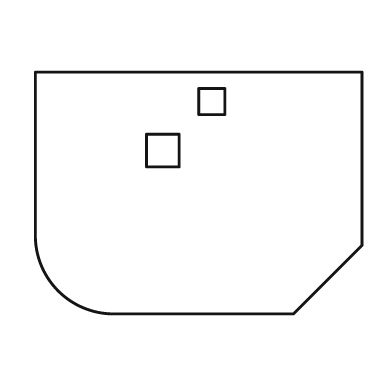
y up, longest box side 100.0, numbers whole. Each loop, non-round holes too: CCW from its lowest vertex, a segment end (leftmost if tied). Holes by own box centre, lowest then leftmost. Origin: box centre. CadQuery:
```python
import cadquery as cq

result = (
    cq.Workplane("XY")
    .moveTo(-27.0, -37.0)
    .lineTo(29.0, -37.0)
    .lineTo(50.0, -16.0)
    .lineTo(50.0, 37.0)
    .lineTo(-50.0, 37.0)
    .lineTo(-50.0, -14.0)
    .threePointArc((-43.0, -30.0), (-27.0, -37.0))
    .close()
    .moveTo(-16.0, 8.0)
    .lineTo(-6.0, 8.0)
    .lineTo(-6.0, 18.0)
    .lineTo(-16.0, 18.0)
    .close()
    .moveTo(0.0, 24.0)
    .lineTo(8.0, 24.0)
    .lineTo(8.0, 32.0)
    .lineTo(0.0, 32.0)
    .close()
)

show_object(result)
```